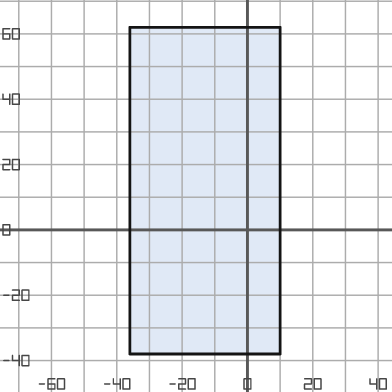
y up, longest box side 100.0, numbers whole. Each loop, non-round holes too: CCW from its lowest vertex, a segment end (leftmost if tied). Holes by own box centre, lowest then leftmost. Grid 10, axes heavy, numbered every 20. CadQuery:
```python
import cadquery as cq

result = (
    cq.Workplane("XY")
    .moveTo(-36.0, -38.0)
    .lineTo(10.0, -38.0)
    .lineTo(10.0, 62.0)
    .lineTo(-36.0, 62.0)
    .close()
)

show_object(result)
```